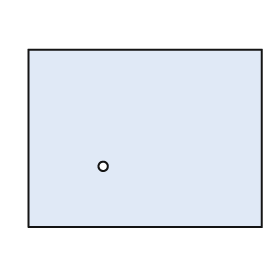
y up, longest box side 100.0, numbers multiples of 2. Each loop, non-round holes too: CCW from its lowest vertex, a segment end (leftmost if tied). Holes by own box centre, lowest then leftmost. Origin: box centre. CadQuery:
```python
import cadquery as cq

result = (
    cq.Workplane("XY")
    .moveTo(-50.0, -38.0)
    .lineTo(50.0, -38.0)
    .lineTo(50.0, 38.0)
    .lineTo(-50.0, 38.0)
    .close()
    .moveTo(-18.0, -12.0)
    .circle(2.0)
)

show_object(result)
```